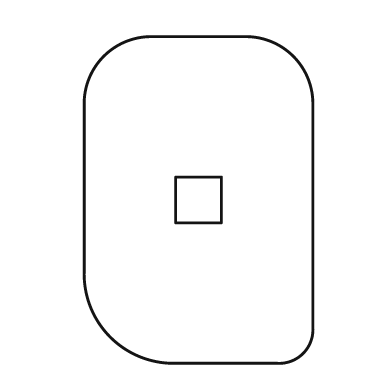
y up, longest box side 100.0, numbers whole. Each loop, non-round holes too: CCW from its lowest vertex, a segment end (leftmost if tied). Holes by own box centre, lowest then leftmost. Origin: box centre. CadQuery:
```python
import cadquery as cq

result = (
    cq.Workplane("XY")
    .moveTo(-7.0, -50.0)
    .lineTo(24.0, -50.0)
    .threePointArc((32.0, -47.0), (35.0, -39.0))
    .lineTo(35.0, 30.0)
    .threePointArc((29.0, 44.0), (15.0, 50.0))
    .lineTo(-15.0, 50.0)
    .threePointArc((-29.0, 44.0), (-35.0, 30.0))
    .lineTo(-35.0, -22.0)
    .threePointArc((-27.0, -42.0), (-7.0, -50.0))
    .close()
    .moveTo(-7.0, -7.0)
    .lineTo(7.0, -7.0)
    .lineTo(7.0, 7.0)
    .lineTo(-7.0, 7.0)
    .close()
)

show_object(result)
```